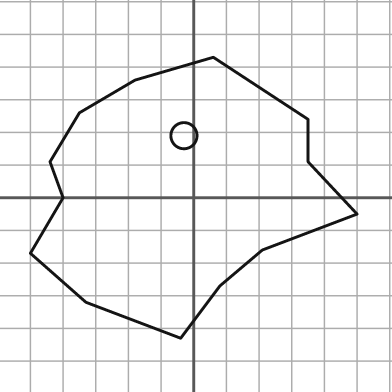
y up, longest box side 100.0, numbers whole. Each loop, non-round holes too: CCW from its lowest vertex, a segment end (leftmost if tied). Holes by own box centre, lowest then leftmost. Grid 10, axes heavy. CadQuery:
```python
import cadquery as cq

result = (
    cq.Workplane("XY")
    .moveTo(-4.0, -43.0)
    .lineTo(8.0, -27.0)
    .lineTo(21.0, -16.0)
    .lineTo(50.0, -5.0)
    .lineTo(35.0, 11.0)
    .lineTo(35.0, 24.0)
    .lineTo(6.0, 43.0)
    .lineTo(-18.0, 36.0)
    .lineTo(-35.0, 26.0)
    .lineTo(-44.0, 11.0)
    .lineTo(-40.0, 0.0)
    .lineTo(-50.0, -17.0)
    .lineTo(-33.0, -32.0)
    .close()
    .moveTo(-3.0, 19.0)
    .circle(4.0)
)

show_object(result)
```